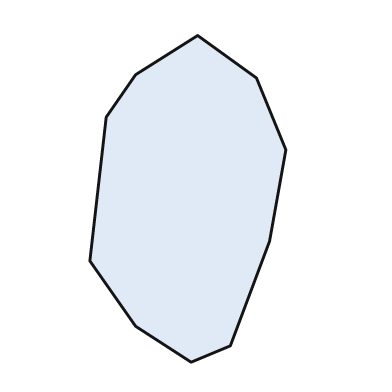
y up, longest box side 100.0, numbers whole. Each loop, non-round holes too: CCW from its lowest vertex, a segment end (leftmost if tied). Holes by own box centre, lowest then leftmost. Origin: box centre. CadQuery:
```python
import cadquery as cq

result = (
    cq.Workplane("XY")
    .moveTo(1.0, -50.0)
    .lineTo(13.0, -45.0)
    .lineTo(25.0, -13.0)
    .lineTo(30.0, 15.0)
    .lineTo(21.0, 37.0)
    .lineTo(3.0, 50.0)
    .lineTo(-16.0, 38.0)
    .lineTo(-25.0, 25.0)
    .lineTo(-30.0, -19.0)
    .lineTo(-16.0, -39.0)
    .close()
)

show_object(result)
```